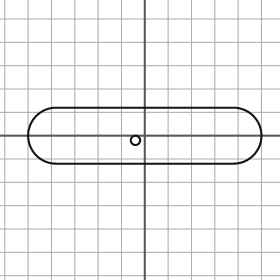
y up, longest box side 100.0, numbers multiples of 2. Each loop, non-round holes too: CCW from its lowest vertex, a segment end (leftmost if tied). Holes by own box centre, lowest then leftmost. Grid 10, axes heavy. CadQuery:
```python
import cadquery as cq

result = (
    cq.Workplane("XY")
    .moveTo(-38.0, -12.0)
    .lineTo(38.0, -12.0)
    .threePointArc((50.0, 0.0), (38.0, 12.0))
    .lineTo(-38.0, 12.0)
    .threePointArc((-50.0, 0.0), (-38.0, -12.0))
    .close()
    .moveTo(-4.0, -2.0)
    .circle(2.0)
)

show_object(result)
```